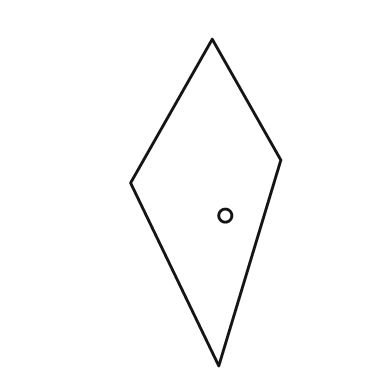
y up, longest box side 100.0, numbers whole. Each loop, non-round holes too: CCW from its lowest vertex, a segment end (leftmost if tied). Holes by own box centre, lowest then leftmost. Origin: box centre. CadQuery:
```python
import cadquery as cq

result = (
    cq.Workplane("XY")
    .moveTo(4.0, -50.0)
    .lineTo(23.0, 13.0)
    .lineTo(2.0, 50.0)
    .lineTo(-23.0, 6.0)
    .close()
    .moveTo(6.0, -4.0)
    .circle(2.0)
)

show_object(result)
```